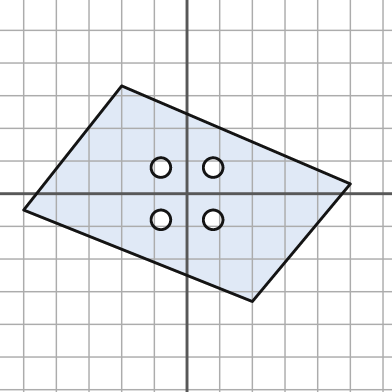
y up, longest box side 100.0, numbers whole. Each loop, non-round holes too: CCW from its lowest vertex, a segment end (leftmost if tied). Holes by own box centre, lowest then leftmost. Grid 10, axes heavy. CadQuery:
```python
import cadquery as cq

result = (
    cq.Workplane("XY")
    .moveTo(20.0, -33.0)
    .lineTo(50.0, 3.0)
    .lineTo(-20.0, 33.0)
    .lineTo(-50.0, -5.0)
    .close()
    .moveTo(-8.0, -8.0)
    .circle(3.0)
    .moveTo(8.0, -8.0)
    .circle(3.0)
    .moveTo(-8.0, 8.0)
    .circle(3.0)
    .moveTo(8.0, 8.0)
    .circle(3.0)
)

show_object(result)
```